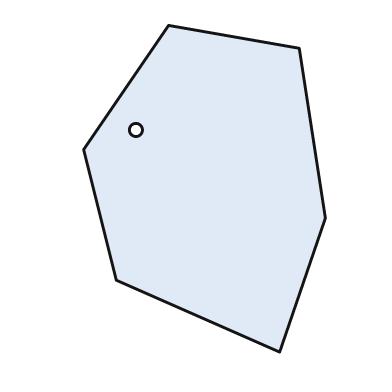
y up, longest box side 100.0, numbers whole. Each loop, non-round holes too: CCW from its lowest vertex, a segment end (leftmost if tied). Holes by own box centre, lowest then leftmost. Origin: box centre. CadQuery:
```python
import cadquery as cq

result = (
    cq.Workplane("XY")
    .moveTo(23.0, -50.0)
    .lineTo(37.0, -9.0)
    .lineTo(29.0, 43.0)
    .lineTo(-11.0, 50.0)
    .lineTo(-37.0, 12.0)
    .lineTo(-27.0, -28.0)
    .close()
    .moveTo(-21.0, 18.0)
    .circle(2.0)
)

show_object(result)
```